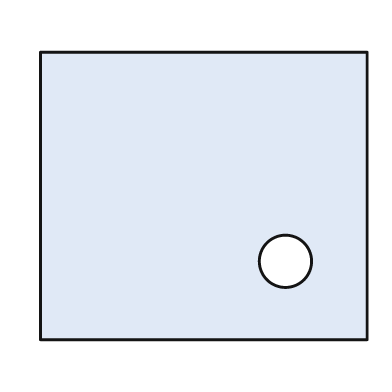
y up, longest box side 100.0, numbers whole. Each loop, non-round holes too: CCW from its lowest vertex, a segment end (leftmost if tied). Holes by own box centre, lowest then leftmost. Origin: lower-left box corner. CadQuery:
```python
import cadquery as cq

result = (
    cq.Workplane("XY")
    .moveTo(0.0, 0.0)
    .lineTo(100.0, 0.0)
    .lineTo(100.0, 88.0)
    .lineTo(0.0, 88.0)
    .close()
    .moveTo(75.0, 24.0)
    .circle(8.0)
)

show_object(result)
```